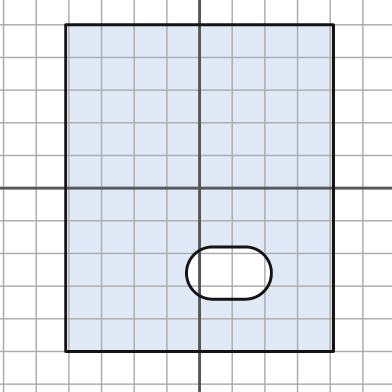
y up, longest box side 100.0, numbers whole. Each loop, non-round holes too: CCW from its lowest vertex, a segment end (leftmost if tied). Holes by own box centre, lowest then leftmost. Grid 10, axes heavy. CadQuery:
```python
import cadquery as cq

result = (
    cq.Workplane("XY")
    .moveTo(-41.0, -50.0)
    .lineTo(41.0, -50.0)
    .lineTo(41.0, 50.0)
    .lineTo(-41.0, 50.0)
    .close()
    .moveTo(4.0, -34.0)
    .lineTo(14.0, -34.0)
    .threePointArc((22.0, -26.0), (14.0, -18.0))
    .lineTo(4.0, -18.0)
    .threePointArc((-4.0, -26.0), (4.0, -34.0))
    .close()
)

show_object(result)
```